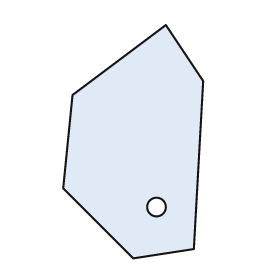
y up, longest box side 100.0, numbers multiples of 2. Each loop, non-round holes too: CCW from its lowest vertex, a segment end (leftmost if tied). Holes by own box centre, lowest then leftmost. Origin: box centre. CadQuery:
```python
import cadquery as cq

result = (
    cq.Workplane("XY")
    .moveTo(0.0, -50.0)
    .lineTo(26.0, -46.0)
    .lineTo(30.0, 26.0)
    .lineTo(14.0, 50.0)
    .lineTo(-26.0, 20.0)
    .lineTo(-30.0, -20.0)
    .close()
    .moveTo(10.0, -28.0)
    .circle(4.0)
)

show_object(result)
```